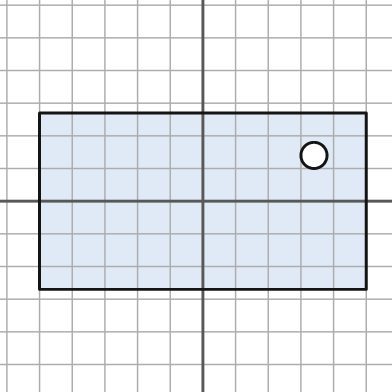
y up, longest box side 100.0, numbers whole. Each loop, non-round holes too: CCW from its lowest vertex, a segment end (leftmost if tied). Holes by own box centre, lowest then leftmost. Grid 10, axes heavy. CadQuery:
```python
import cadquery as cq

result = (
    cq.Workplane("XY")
    .moveTo(-50.0, -27.0)
    .lineTo(50.0, -27.0)
    .lineTo(50.0, 27.0)
    .lineTo(-50.0, 27.0)
    .close()
    .moveTo(34.0, 14.0)
    .circle(4.0)
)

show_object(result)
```